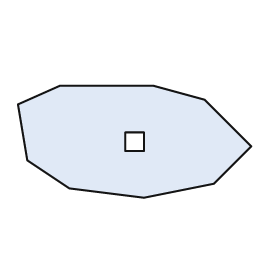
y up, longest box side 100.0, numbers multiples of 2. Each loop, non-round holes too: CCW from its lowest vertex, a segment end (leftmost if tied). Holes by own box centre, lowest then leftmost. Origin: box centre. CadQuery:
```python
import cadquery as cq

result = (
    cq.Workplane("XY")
    .moveTo(4.0, -24.0)
    .lineTo(34.0, -18.0)
    .lineTo(50.0, -2.0)
    .lineTo(30.0, 18.0)
    .lineTo(8.0, 24.0)
    .lineTo(-32.0, 24.0)
    .lineTo(-50.0, 16.0)
    .lineTo(-46.0, -8.0)
    .lineTo(-28.0, -20.0)
    .close()
    .moveTo(-4.0, -4.0)
    .lineTo(4.0, -4.0)
    .lineTo(4.0, 4.0)
    .lineTo(-4.0, 4.0)
    .close()
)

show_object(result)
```